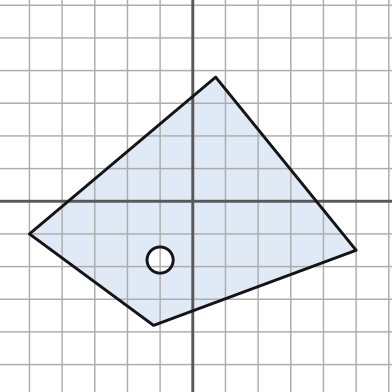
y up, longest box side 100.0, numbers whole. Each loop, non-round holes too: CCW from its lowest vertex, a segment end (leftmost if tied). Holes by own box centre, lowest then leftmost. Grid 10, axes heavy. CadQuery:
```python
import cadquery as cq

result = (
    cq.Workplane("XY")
    .moveTo(-12.0, -38.0)
    .lineTo(50.0, -15.0)
    .lineTo(7.0, 38.0)
    .lineTo(-50.0, -10.0)
    .close()
    .moveTo(-10.0, -18.0)
    .circle(4.0)
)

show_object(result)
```